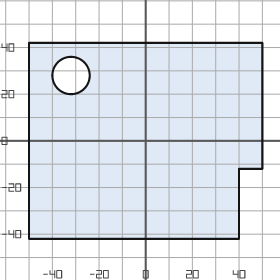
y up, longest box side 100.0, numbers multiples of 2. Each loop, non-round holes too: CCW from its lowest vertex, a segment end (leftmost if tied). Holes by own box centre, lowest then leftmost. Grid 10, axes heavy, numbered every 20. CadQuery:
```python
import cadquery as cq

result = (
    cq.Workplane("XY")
    .moveTo(-50.0, -42.0)
    .lineTo(40.0, -42.0)
    .lineTo(40.0, -12.0)
    .lineTo(50.0, -12.0)
    .lineTo(50.0, 42.0)
    .lineTo(-50.0, 42.0)
    .close()
    .moveTo(-32.0, 28.0)
    .circle(8.0)
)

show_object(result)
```